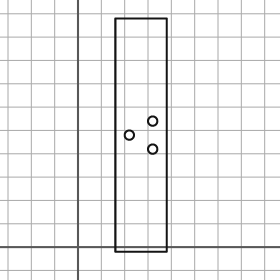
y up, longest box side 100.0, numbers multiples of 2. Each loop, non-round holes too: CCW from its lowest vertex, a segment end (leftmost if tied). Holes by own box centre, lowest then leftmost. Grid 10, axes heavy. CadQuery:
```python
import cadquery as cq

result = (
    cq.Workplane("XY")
    .moveTo(16.0, -2.0)
    .lineTo(38.0, -2.0)
    .lineTo(38.0, 98.0)
    .lineTo(16.0, 98.0)
    .close()
    .moveTo(32.0, 42.0)
    .circle(2.0)
    .moveTo(22.0, 48.0)
    .circle(2.0)
    .moveTo(32.0, 54.0)
    .circle(2.0)
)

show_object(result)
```